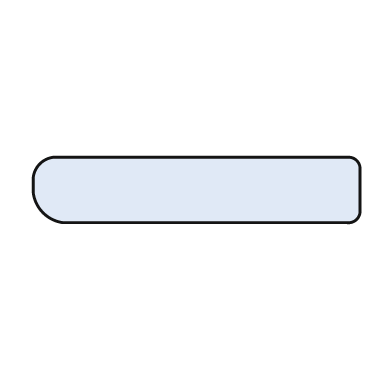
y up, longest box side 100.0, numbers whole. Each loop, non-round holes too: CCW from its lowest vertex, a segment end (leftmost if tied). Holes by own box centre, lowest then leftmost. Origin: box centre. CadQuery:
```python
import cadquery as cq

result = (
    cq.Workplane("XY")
    .moveTo(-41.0, -10.0)
    .lineTo(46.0, -10.0)
    .threePointArc((49.0, -9.0), (50.0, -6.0))
    .lineTo(50.0, 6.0)
    .threePointArc((49.0, 9.0), (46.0, 10.0))
    .lineTo(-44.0, 10.0)
    .threePointArc((-48.0, 8.0), (-50.0, 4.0))
    .lineTo(-50.0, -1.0)
    .threePointArc((-47.0, -7.0), (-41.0, -10.0))
    .close()
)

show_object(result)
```